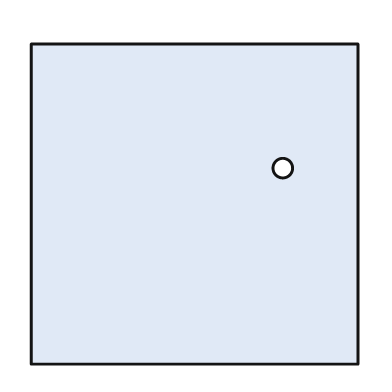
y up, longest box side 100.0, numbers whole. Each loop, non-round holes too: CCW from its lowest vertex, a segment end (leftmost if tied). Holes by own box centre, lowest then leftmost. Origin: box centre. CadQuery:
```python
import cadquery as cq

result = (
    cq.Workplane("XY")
    .moveTo(-50.0, -49.0)
    .lineTo(50.0, -49.0)
    .lineTo(50.0, 49.0)
    .lineTo(-50.0, 49.0)
    .close()
    .moveTo(27.0, 11.0)
    .circle(3.0)
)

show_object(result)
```